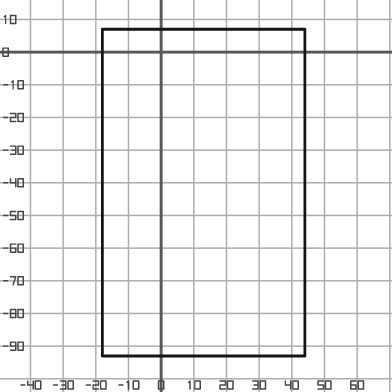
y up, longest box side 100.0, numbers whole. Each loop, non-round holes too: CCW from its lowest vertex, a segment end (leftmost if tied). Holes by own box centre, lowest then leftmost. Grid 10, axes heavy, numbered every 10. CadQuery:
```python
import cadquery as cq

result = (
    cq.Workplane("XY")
    .moveTo(-18.0, -93.0)
    .lineTo(44.0, -93.0)
    .lineTo(44.0, 7.0)
    .lineTo(-18.0, 7.0)
    .close()
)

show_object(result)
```